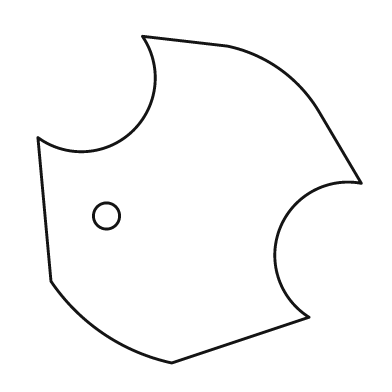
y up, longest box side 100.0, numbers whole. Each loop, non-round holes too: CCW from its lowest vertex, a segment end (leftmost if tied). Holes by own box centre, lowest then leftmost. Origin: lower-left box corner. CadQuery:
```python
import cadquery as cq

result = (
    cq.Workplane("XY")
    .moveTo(41.0, 0.0)
    .lineTo(83.0, 14.0)
    .threePointArc((74.0, 41.0), (99.0, 55.0))
    .lineTo(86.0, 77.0)
    .threePointArc((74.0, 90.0), (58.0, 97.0))
    .lineTo(32.0, 100.0)
    .threePointArc((29.0, 71.0), (0.0, 69.0))
    .lineTo(4.0, 25.0)
    .threePointArc((20.0, 9.0), (41.0, 0.0))
    .close()
    .moveTo(21.0, 45.0)
    .circle(4.0)
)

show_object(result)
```